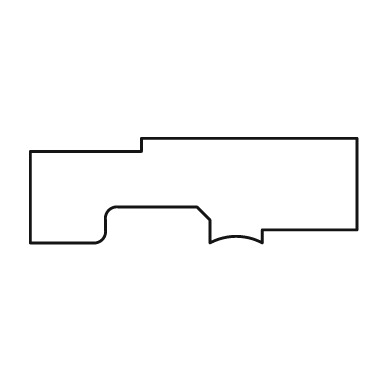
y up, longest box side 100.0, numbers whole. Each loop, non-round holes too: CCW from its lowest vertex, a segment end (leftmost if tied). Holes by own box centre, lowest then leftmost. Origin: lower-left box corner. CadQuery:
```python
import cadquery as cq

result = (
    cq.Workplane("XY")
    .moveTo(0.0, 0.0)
    .lineTo(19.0, 0.0)
    .threePointArc((22.0, 1.0), (23.0, 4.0))
    .lineTo(23.0, 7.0)
    .threePointArc((24.0, 10.0), (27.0, 11.0))
    .lineTo(51.0, 11.0)
    .lineTo(55.0, 7.0)
    .lineTo(55.0, 0.0)
    .threePointArc((63.0, 2.0), (71.0, 0.0))
    .lineTo(71.0, 4.0)
    .lineTo(100.0, 4.0)
    .lineTo(100.0, 32.0)
    .lineTo(34.0, 32.0)
    .lineTo(34.0, 28.0)
    .lineTo(0.0, 28.0)
    .close()
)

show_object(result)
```